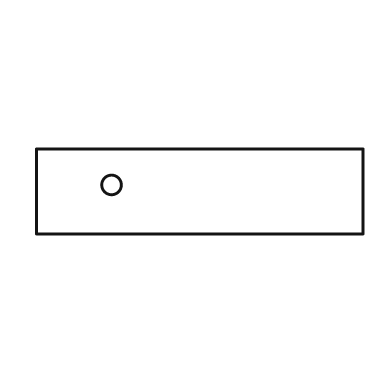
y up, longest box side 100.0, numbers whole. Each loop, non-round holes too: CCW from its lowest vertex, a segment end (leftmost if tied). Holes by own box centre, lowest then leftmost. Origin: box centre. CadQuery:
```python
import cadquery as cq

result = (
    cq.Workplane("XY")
    .moveTo(-50.0, -13.0)
    .lineTo(50.0, -13.0)
    .lineTo(50.0, 13.0)
    .lineTo(-50.0, 13.0)
    .close()
    .moveTo(-27.0, 2.0)
    .circle(3.0)
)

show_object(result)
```